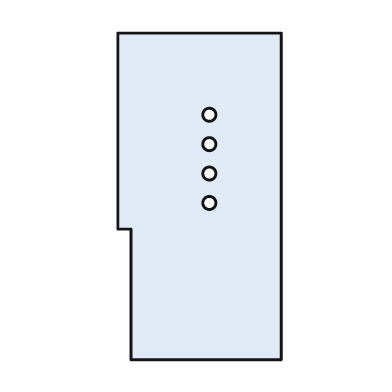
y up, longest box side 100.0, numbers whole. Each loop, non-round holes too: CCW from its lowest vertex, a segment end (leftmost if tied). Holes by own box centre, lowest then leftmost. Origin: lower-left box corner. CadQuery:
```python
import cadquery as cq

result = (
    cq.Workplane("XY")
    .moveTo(4.0, 0.0)
    .lineTo(50.0, 0.0)
    .lineTo(50.0, 100.0)
    .lineTo(0.0, 100.0)
    .lineTo(0.0, 40.0)
    .lineTo(4.0, 40.0)
    .close()
    .moveTo(28.0, 48.0)
    .circle(2.0)
    .moveTo(28.0, 57.0)
    .circle(2.0)
    .moveTo(28.0, 66.0)
    .circle(2.0)
    .moveTo(28.0, 75.0)
    .circle(2.0)
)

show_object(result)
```